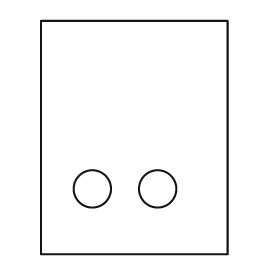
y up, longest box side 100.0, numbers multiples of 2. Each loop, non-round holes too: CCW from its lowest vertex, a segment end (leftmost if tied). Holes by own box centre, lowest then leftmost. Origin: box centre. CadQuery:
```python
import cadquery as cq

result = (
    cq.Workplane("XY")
    .moveTo(-40.0, -50.0)
    .lineTo(40.0, -50.0)
    .lineTo(40.0, 50.0)
    .lineTo(-40.0, 50.0)
    .close()
    .moveTo(-18.0, -22.0)
    .circle(8.0)
    .moveTo(10.0, -22.0)
    .circle(8.0)
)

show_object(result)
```